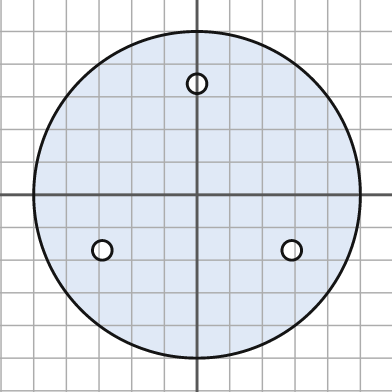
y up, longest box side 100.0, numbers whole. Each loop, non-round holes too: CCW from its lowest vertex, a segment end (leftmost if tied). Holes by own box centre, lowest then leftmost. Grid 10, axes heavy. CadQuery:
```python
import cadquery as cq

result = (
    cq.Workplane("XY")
    .moveTo(0.0, 0.0)
    .circle(50.0)
    .moveTo(-29.0, -17.0)
    .circle(3.0)
    .moveTo(29.0, -17.0)
    .circle(3.0)
    .moveTo(0.0, 34.0)
    .circle(3.0)
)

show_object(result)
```